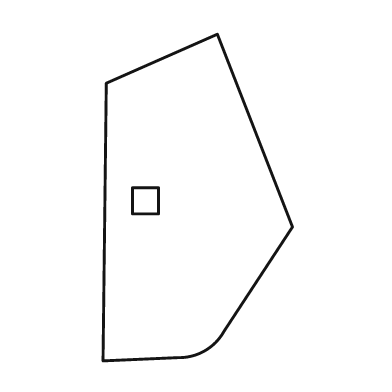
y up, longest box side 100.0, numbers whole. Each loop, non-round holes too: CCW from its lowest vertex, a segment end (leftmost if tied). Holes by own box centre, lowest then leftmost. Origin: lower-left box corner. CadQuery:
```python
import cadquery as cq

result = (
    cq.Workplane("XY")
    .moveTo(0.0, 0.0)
    .lineTo(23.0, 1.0)
    .threePointArc((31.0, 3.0), (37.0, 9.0))
    .lineTo(58.0, 41.0)
    .lineTo(35.0, 100.0)
    .lineTo(1.0, 85.0)
    .close()
    .moveTo(9.0, 45.0)
    .lineTo(17.0, 45.0)
    .lineTo(17.0, 53.0)
    .lineTo(9.0, 53.0)
    .close()
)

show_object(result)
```